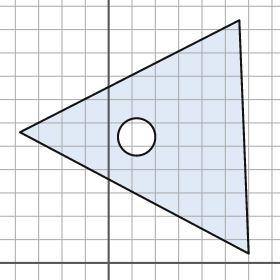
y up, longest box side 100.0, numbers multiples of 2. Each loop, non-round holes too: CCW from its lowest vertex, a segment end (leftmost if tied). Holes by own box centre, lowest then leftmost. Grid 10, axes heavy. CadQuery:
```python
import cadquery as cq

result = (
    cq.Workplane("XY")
    .moveTo(60.0, 4.0)
    .lineTo(56.0, 104.0)
    .lineTo(-38.0, 56.0)
    .close()
    .moveTo(12.0, 54.0)
    .circle(8.0)
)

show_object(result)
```